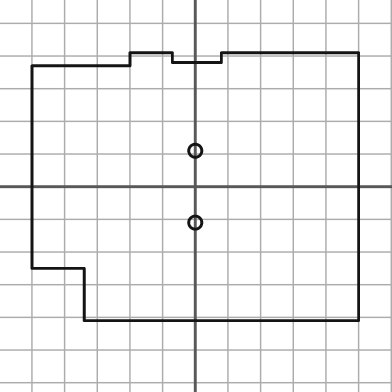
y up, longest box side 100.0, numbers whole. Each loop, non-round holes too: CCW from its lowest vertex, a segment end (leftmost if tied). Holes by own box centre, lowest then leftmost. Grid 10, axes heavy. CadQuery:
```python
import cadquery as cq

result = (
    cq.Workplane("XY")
    .moveTo(-34.0, -41.0)
    .lineTo(50.0, -41.0)
    .lineTo(50.0, 41.0)
    .lineTo(8.0, 41.0)
    .lineTo(8.0, 38.0)
    .lineTo(-7.0, 38.0)
    .lineTo(-7.0, 41.0)
    .lineTo(-20.0, 41.0)
    .lineTo(-20.0, 37.0)
    .lineTo(-50.0, 37.0)
    .lineTo(-50.0, -25.0)
    .lineTo(-34.0, -25.0)
    .close()
    .moveTo(0.0, -11.0)
    .circle(2.0)
    .moveTo(0.0, 11.0)
    .circle(2.0)
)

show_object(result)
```